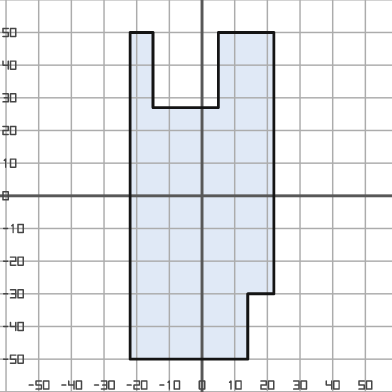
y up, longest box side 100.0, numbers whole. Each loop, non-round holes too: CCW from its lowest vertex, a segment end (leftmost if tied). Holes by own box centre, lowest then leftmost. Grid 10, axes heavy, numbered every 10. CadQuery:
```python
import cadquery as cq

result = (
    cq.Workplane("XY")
    .moveTo(-22.0, -50.0)
    .lineTo(14.0, -50.0)
    .lineTo(14.0, -30.0)
    .lineTo(22.0, -30.0)
    .lineTo(22.0, 50.0)
    .lineTo(5.0, 50.0)
    .lineTo(5.0, 27.0)
    .lineTo(-15.0, 27.0)
    .lineTo(-15.0, 50.0)
    .lineTo(-22.0, 50.0)
    .close()
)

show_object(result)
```